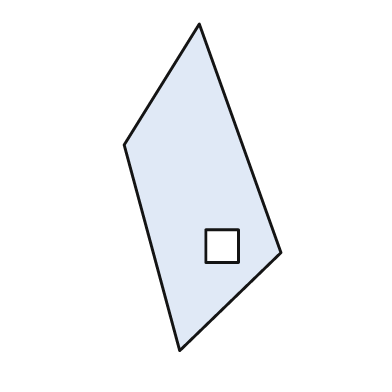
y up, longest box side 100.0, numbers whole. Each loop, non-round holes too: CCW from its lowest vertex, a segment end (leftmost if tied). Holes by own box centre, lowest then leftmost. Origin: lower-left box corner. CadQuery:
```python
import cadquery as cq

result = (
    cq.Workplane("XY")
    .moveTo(17.0, 0.0)
    .lineTo(48.0, 30.0)
    .lineTo(23.0, 100.0)
    .lineTo(0.0, 63.0)
    .close()
    .moveTo(25.0, 27.0)
    .lineTo(35.0, 27.0)
    .lineTo(35.0, 37.0)
    .lineTo(25.0, 37.0)
    .close()
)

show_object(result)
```